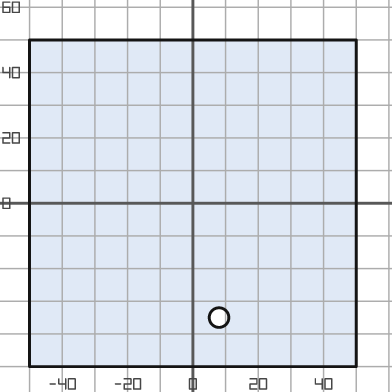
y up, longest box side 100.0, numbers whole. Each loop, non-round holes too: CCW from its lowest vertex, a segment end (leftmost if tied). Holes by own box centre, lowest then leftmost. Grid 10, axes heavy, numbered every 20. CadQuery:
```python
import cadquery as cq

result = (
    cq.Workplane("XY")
    .moveTo(-50.0, -50.0)
    .lineTo(50.0, -50.0)
    .lineTo(50.0, 50.0)
    .lineTo(-50.0, 50.0)
    .close()
    .moveTo(8.0, -35.0)
    .circle(3.0)
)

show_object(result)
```